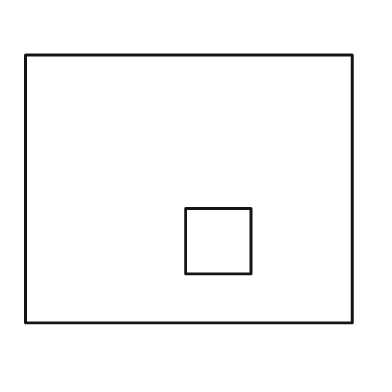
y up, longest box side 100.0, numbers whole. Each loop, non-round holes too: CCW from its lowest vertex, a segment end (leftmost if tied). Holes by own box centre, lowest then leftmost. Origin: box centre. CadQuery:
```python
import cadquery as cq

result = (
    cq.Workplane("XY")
    .moveTo(-50.0, -41.0)
    .lineTo(50.0, -41.0)
    .lineTo(50.0, 41.0)
    .lineTo(-50.0, 41.0)
    .close()
    .moveTo(-1.0, -26.0)
    .lineTo(19.0, -26.0)
    .lineTo(19.0, -6.0)
    .lineTo(-1.0, -6.0)
    .close()
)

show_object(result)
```